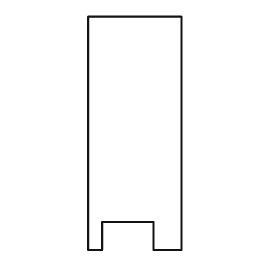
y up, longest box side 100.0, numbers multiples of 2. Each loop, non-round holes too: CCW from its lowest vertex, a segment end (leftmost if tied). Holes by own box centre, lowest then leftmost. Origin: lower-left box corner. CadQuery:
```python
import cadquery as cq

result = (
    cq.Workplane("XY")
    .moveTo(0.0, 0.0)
    .lineTo(6.0, 0.0)
    .lineTo(6.0, 12.0)
    .lineTo(28.0, 12.0)
    .lineTo(28.0, 0.0)
    .lineTo(40.0, 0.0)
    .lineTo(40.0, 100.0)
    .lineTo(0.0, 100.0)
    .close()
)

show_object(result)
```